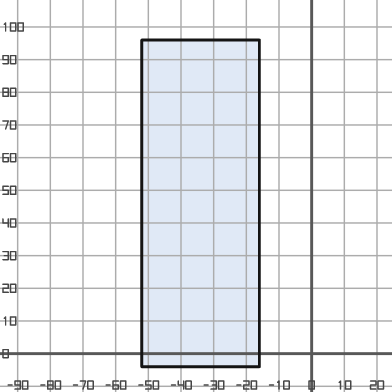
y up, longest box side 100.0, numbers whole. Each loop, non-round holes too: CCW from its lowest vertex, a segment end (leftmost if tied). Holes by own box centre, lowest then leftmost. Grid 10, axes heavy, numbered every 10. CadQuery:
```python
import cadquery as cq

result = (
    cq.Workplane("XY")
    .moveTo(-52.0, -4.0)
    .lineTo(-16.0, -4.0)
    .lineTo(-16.0, 96.0)
    .lineTo(-52.0, 96.0)
    .close()
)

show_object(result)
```